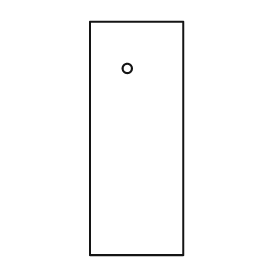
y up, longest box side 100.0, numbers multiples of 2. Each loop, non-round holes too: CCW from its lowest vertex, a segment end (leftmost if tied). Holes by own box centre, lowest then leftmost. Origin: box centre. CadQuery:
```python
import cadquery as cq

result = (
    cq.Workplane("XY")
    .moveTo(-20.0, -50.0)
    .lineTo(20.0, -50.0)
    .lineTo(20.0, 50.0)
    .lineTo(-20.0, 50.0)
    .close()
    .moveTo(-4.0, 30.0)
    .circle(2.0)
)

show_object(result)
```